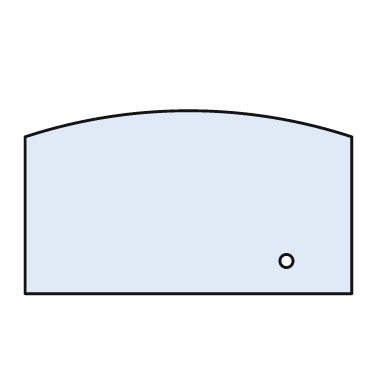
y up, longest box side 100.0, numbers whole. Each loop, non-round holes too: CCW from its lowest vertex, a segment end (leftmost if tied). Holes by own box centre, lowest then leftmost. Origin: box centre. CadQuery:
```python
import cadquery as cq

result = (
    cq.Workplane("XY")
    .moveTo(-50.0, -28.0)
    .lineTo(50.0, -28.0)
    .lineTo(50.0, 20.0)
    .threePointArc((0.0, 28.0), (-50.0, 20.0))
    .close()
    .moveTo(30.0, -18.0)
    .circle(2.0)
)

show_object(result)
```